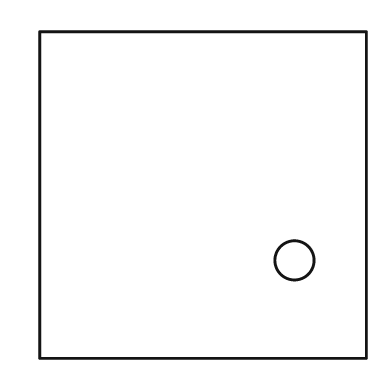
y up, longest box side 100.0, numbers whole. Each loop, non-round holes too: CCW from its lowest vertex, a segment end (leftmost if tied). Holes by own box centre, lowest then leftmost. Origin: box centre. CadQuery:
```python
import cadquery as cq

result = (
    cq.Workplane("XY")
    .moveTo(-50.0, -50.0)
    .lineTo(50.0, -50.0)
    .lineTo(50.0, 50.0)
    .lineTo(-50.0, 50.0)
    .close()
    .moveTo(28.0, -20.0)
    .circle(6.0)
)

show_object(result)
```